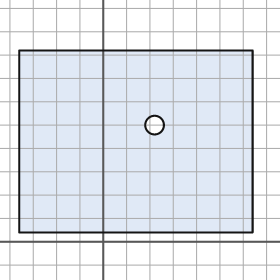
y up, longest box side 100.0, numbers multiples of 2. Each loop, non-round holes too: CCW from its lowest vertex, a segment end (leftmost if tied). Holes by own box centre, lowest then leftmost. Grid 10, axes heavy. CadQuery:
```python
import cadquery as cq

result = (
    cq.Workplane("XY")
    .moveTo(-36.0, 4.0)
    .lineTo(64.0, 4.0)
    .lineTo(64.0, 82.0)
    .lineTo(-36.0, 82.0)
    .close()
    .moveTo(22.0, 50.0)
    .circle(4.0)
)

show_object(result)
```